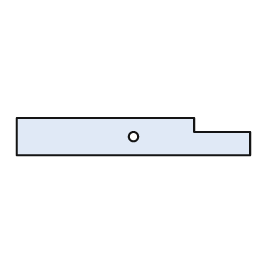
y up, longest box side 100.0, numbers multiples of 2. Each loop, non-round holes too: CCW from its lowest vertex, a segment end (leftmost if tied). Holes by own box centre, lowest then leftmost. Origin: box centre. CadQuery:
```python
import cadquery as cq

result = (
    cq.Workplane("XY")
    .moveTo(-50.0, -8.0)
    .lineTo(50.0, -8.0)
    .lineTo(50.0, 2.0)
    .lineTo(26.0, 2.0)
    .lineTo(26.0, 8.0)
    .lineTo(-50.0, 8.0)
    .close()
    .moveTo(0.0, 0.0)
    .circle(2.0)
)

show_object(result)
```